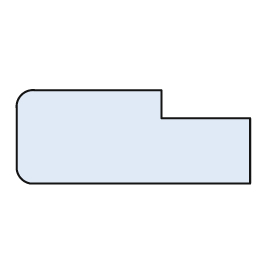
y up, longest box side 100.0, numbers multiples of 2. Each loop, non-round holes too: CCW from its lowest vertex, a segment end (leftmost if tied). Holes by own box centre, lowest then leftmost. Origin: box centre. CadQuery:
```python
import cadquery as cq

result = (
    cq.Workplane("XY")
    .moveTo(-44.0, -20.0)
    .lineTo(50.0, -20.0)
    .lineTo(50.0, 8.0)
    .lineTo(12.0, 8.0)
    .lineTo(12.0, 20.0)
    .lineTo(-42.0, 20.0)
    .threePointArc((-48.0, 18.0), (-50.0, 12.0))
    .lineTo(-50.0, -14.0)
    .threePointArc((-48.0, -18.0), (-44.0, -20.0))
    .close()
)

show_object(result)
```